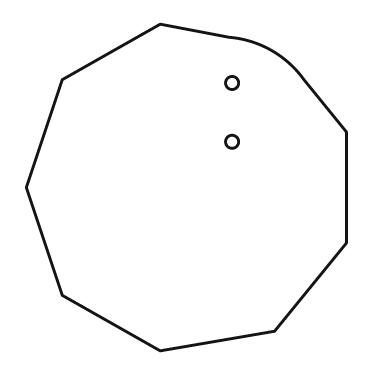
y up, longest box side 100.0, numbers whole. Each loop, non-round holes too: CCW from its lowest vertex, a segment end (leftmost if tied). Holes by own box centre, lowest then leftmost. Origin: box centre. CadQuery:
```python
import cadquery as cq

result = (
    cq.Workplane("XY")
    .moveTo(-8.0, -50.0)
    .lineTo(27.0, -44.0)
    .lineTo(49.0, -17.0)
    .lineTo(49.0, 17.0)
    .lineTo(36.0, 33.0)
    .threePointArc((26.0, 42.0), (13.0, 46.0))
    .lineTo(-8.0, 50.0)
    .lineTo(-38.0, 33.0)
    .lineTo(-49.0, 0.0)
    .lineTo(-38.0, -33.0)
    .close()
    .moveTo(14.0, 14.0)
    .circle(2.0)
    .moveTo(14.0, 32.0)
    .circle(2.0)
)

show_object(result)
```